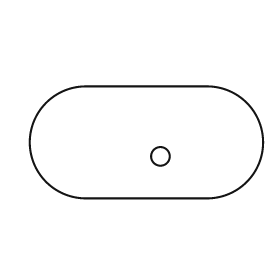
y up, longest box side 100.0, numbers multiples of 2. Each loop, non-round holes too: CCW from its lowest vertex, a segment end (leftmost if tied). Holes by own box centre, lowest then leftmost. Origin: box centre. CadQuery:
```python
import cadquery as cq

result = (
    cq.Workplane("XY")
    .moveTo(-26.0, -24.0)
    .lineTo(26.0, -24.0)
    .threePointArc((50.0, 0.0), (26.0, 24.0))
    .lineTo(-26.0, 24.0)
    .threePointArc((-50.0, 0.0), (-26.0, -24.0))
    .close()
    .moveTo(6.0, -6.0)
    .circle(4.0)
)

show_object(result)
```